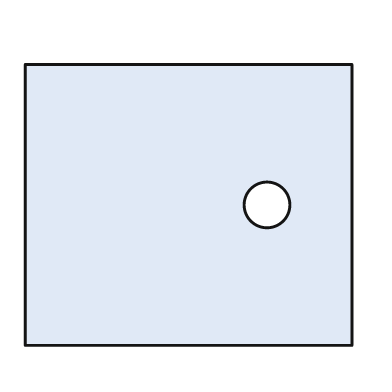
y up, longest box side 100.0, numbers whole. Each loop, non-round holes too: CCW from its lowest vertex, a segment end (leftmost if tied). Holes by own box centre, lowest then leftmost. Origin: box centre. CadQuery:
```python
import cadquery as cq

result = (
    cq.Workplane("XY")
    .moveTo(-50.0, -43.0)
    .lineTo(50.0, -43.0)
    .lineTo(50.0, 43.0)
    .lineTo(-50.0, 43.0)
    .close()
    .moveTo(24.0, 0.0)
    .circle(7.0)
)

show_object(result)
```